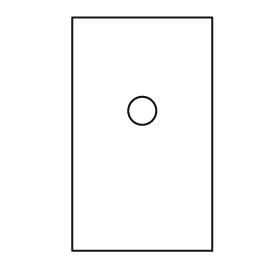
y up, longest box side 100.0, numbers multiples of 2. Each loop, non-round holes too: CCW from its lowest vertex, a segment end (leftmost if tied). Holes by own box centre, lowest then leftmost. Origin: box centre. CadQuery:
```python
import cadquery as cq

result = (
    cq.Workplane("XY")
    .moveTo(-30.0, -50.0)
    .lineTo(30.0, -50.0)
    .lineTo(30.0, 50.0)
    .lineTo(-30.0, 50.0)
    .close()
    .moveTo(0.0, 10.0)
    .circle(6.0)
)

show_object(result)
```